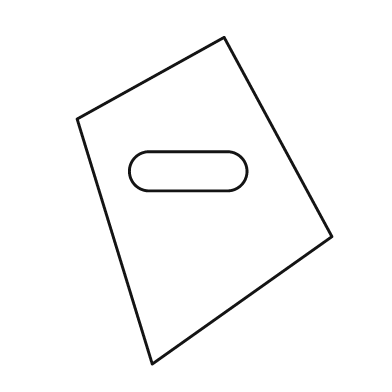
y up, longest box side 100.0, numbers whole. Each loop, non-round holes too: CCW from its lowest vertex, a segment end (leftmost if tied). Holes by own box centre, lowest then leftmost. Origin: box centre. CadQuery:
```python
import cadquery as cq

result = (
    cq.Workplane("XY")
    .moveTo(-16.0, -50.0)
    .lineTo(39.0, -11.0)
    .lineTo(6.0, 50.0)
    .lineTo(-39.0, 25.0)
    .close()
    .moveTo(-17.0, 3.0)
    .lineTo(7.0, 3.0)
    .threePointArc((13.0, 9.0), (7.0, 15.0))
    .lineTo(-17.0, 15.0)
    .threePointArc((-23.0, 9.0), (-17.0, 3.0))
    .close()
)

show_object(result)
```